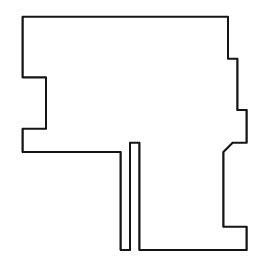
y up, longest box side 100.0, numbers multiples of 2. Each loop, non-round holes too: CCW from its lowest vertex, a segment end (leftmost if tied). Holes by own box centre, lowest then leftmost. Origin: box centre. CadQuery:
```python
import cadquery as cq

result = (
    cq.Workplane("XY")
    .moveTo(-6.0, -50.0)
    .lineTo(-2.0, -50.0)
    .lineTo(-2.0, -4.0)
    .lineTo(2.0, -4.0)
    .lineTo(2.0, -50.0)
    .lineTo(48.0, -50.0)
    .lineTo(48.0, -40.0)
    .lineTo(38.0, -40.0)
    .lineTo(38.0, -8.0)
    .lineTo(42.0, -4.0)
    .lineTo(48.0, -4.0)
    .lineTo(48.0, 10.0)
    .lineTo(44.0, 10.0)
    .lineTo(44.0, 32.0)
    .lineTo(40.0, 32.0)
    .lineTo(40.0, 50.0)
    .lineTo(-48.0, 50.0)
    .lineTo(-48.0, 24.0)
    .lineTo(-38.0, 24.0)
    .lineTo(-38.0, 2.0)
    .lineTo(-48.0, 2.0)
    .lineTo(-48.0, -8.0)
    .lineTo(-6.0, -8.0)
    .close()
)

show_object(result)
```